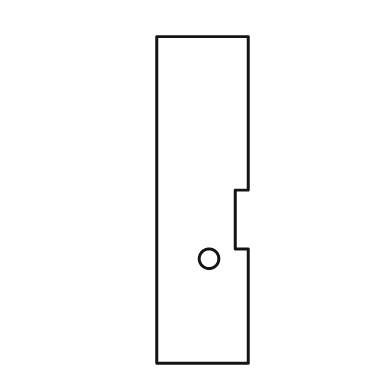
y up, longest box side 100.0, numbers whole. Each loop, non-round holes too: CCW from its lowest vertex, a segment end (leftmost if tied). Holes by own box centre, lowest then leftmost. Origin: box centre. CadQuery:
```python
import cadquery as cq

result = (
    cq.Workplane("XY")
    .moveTo(-14.0, -50.0)
    .lineTo(14.0, -50.0)
    .lineTo(14.0, -15.0)
    .lineTo(10.0, -15.0)
    .lineTo(10.0, 3.0)
    .lineTo(14.0, 3.0)
    .lineTo(14.0, 50.0)
    .lineTo(-14.0, 50.0)
    .close()
    .moveTo(2.0, -18.0)
    .circle(3.0)
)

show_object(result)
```